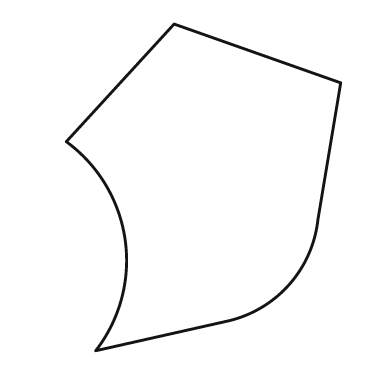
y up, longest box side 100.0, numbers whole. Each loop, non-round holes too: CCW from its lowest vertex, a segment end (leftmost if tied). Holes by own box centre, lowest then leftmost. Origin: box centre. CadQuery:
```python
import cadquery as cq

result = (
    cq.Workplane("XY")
    .moveTo(-33.0, -50.0)
    .lineTo(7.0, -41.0)
    .threePointArc((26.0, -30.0), (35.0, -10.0))
    .lineTo(42.0, 32.0)
    .lineTo(-9.0, 50.0)
    .lineTo(-42.0, 14.0)
    .threePointArc((-24.0, -16.0), (-33.0, -50.0))
    .close()
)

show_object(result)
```